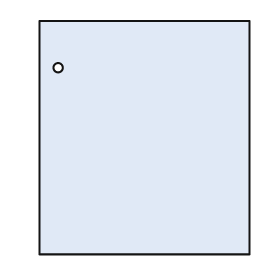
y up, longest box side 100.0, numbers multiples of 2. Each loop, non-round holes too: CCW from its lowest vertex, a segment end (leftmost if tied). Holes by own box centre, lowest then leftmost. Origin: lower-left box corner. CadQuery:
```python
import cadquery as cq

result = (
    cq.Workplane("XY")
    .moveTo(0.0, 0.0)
    .lineTo(90.0, 0.0)
    .lineTo(90.0, 100.0)
    .lineTo(0.0, 100.0)
    .close()
    .moveTo(8.0, 80.0)
    .circle(2.0)
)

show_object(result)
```